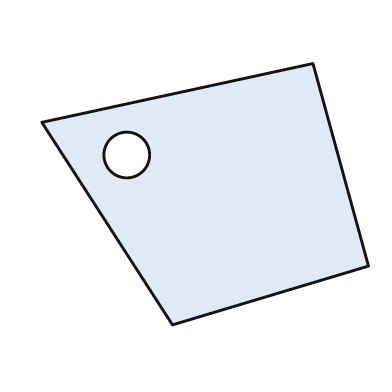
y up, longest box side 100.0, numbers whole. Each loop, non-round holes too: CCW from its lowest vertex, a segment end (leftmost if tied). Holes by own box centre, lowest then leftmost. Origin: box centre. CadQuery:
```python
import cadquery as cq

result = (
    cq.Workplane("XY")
    .moveTo(-10.0, -40.0)
    .lineTo(50.0, -22.0)
    .lineTo(33.0, 40.0)
    .lineTo(-50.0, 22.0)
    .close()
    .moveTo(-24.0, 12.0)
    .circle(7.0)
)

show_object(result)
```